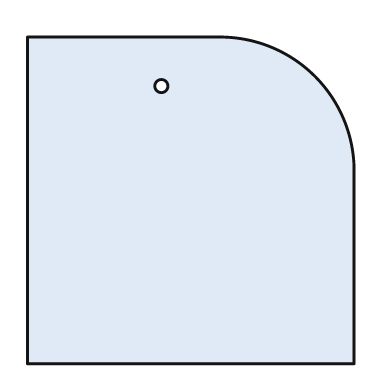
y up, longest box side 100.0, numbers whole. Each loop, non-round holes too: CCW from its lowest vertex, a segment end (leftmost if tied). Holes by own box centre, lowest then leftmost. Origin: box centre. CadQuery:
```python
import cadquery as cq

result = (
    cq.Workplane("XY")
    .moveTo(-50.0, -50.0)
    .lineTo(50.0, -50.0)
    .lineTo(50.0, 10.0)
    .threePointArc((38.0, 38.0), (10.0, 50.0))
    .lineTo(-50.0, 50.0)
    .close()
    .moveTo(-9.0, 35.0)
    .circle(2.0)
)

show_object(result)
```